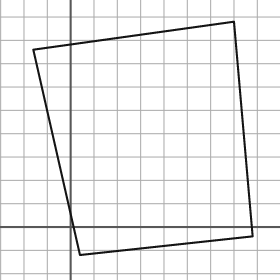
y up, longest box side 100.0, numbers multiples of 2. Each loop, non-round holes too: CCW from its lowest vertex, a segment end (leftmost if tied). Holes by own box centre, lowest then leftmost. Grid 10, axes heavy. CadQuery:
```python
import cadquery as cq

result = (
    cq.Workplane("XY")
    .moveTo(4.0, -12.0)
    .lineTo(78.0, -4.0)
    .lineTo(70.0, 88.0)
    .lineTo(-16.0, 76.0)
    .close()
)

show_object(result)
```